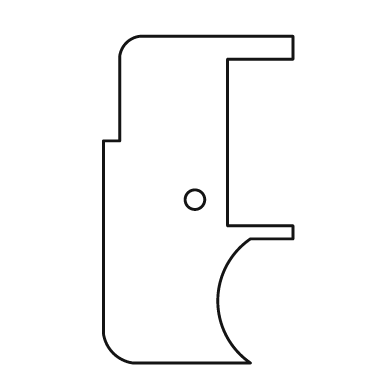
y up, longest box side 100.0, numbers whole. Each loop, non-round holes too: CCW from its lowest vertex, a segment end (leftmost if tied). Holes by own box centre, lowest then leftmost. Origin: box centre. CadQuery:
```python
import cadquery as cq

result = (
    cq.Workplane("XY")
    .moveTo(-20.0, -50.0)
    .lineTo(16.0, -50.0)
    .threePointArc((6.0, -31.0), (16.0, -12.0))
    .lineTo(29.0, -12.0)
    .lineTo(29.0, -8.0)
    .lineTo(9.0, -8.0)
    .lineTo(9.0, 43.0)
    .lineTo(29.0, 43.0)
    .lineTo(29.0, 50.0)
    .lineTo(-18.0, 50.0)
    .threePointArc((-22.0, 48.0), (-24.0, 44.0))
    .lineTo(-24.0, 18.0)
    .lineTo(-29.0, 18.0)
    .lineTo(-29.0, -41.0)
    .threePointArc((-26.0, -47.0), (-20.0, -50.0))
    .close()
    .moveTo(-1.0, 0.0)
    .circle(3.0)
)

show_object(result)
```